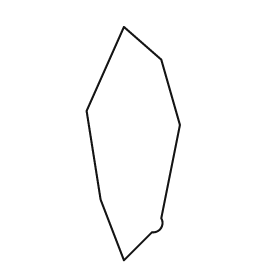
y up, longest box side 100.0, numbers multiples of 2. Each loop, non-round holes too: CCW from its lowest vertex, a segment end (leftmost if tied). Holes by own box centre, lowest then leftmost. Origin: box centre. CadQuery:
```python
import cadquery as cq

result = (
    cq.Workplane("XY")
    .moveTo(-4.0, -50.0)
    .lineTo(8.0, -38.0)
    .threePointArc((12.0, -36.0), (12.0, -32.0))
    .lineTo(20.0, 8.0)
    .lineTo(12.0, 36.0)
    .lineTo(-4.0, 50.0)
    .lineTo(-20.0, 14.0)
    .lineTo(-14.0, -24.0)
    .close()
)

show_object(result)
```